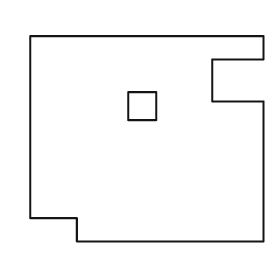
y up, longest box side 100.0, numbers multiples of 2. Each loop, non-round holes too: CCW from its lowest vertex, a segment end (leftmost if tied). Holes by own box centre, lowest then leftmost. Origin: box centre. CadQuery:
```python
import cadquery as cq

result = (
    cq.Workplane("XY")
    .moveTo(-30.0, -44.0)
    .lineTo(50.0, -44.0)
    .lineTo(50.0, 16.0)
    .lineTo(28.0, 16.0)
    .lineTo(28.0, 34.0)
    .lineTo(50.0, 34.0)
    .lineTo(50.0, 44.0)
    .lineTo(-50.0, 44.0)
    .lineTo(-50.0, -34.0)
    .lineTo(-30.0, -34.0)
    .close()
    .moveTo(-8.0, 8.0)
    .lineTo(4.0, 8.0)
    .lineTo(4.0, 20.0)
    .lineTo(-8.0, 20.0)
    .close()
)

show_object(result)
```